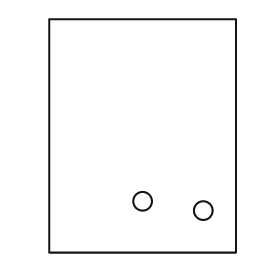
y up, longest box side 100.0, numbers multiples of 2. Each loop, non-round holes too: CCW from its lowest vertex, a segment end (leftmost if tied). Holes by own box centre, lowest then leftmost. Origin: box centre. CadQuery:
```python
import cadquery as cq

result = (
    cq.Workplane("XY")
    .moveTo(-40.0, -50.0)
    .lineTo(40.0, -50.0)
    .lineTo(40.0, 50.0)
    .lineTo(-40.0, 50.0)
    .close()
    .moveTo(26.0, -32.0)
    .circle(4.0)
    .moveTo(0.0, -28.0)
    .circle(4.0)
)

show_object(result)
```